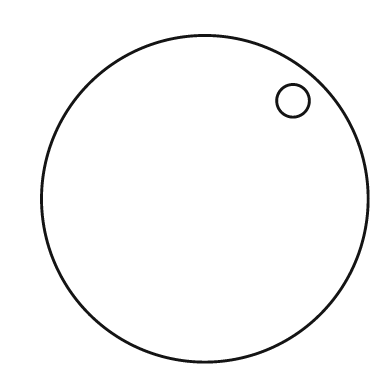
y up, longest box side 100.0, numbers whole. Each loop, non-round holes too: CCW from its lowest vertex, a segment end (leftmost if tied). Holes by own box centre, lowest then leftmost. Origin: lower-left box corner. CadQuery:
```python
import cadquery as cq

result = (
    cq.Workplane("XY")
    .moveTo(50.0, 50.0)
    .circle(50.0)
    .moveTo(77.0, 80.0)
    .circle(5.0)
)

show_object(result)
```